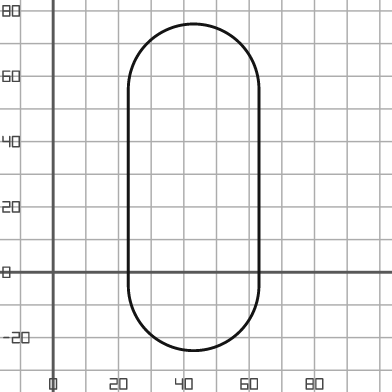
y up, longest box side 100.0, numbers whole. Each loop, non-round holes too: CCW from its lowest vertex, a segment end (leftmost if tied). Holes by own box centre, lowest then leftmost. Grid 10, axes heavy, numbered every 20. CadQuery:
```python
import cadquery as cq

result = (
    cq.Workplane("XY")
    .moveTo(23.0, -4.0)
    .threePointArc((43.0, -24.0), (63.0, -4.0))
    .lineTo(63.0, 56.0)
    .threePointArc((43.0, 76.0), (23.0, 56.0))
    .close()
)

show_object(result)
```